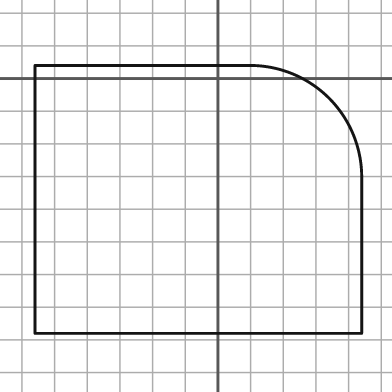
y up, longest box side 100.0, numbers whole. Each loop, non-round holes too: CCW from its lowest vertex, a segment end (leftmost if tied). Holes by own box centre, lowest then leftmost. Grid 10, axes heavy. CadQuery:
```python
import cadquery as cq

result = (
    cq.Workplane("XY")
    .moveTo(-56.0, -78.0)
    .lineTo(44.0, -78.0)
    .lineTo(44.0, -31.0)
    .threePointArc((34.0, -6.0), (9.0, 4.0))
    .lineTo(-56.0, 4.0)
    .close()
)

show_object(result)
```